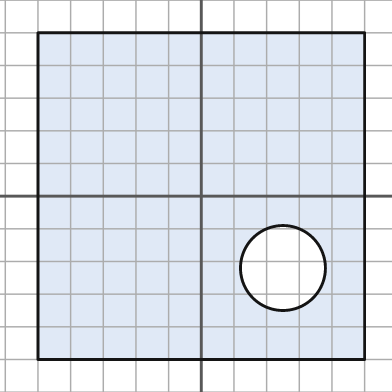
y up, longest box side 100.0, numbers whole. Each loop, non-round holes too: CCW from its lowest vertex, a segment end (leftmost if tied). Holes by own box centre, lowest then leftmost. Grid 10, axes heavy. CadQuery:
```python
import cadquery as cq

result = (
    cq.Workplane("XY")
    .moveTo(-50.0, -50.0)
    .lineTo(50.0, -50.0)
    .lineTo(50.0, 50.0)
    .lineTo(-50.0, 50.0)
    .close()
    .moveTo(25.0, -22.0)
    .circle(13.0)
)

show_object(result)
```